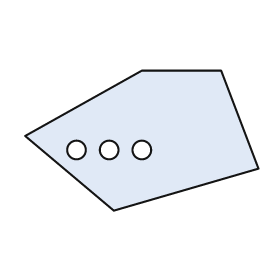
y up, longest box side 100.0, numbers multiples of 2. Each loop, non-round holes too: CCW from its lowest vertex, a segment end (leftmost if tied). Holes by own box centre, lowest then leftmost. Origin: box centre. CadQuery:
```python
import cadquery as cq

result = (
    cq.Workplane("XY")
    .moveTo(-12.0, -30.0)
    .lineTo(50.0, -12.0)
    .lineTo(34.0, 30.0)
    .lineTo(0.0, 30.0)
    .lineTo(-50.0, 2.0)
    .close()
    .moveTo(-28.0, -4.0)
    .circle(4.0)
    .moveTo(-14.0, -4.0)
    .circle(4.0)
    .moveTo(0.0, -4.0)
    .circle(4.0)
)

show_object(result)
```